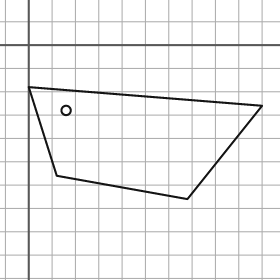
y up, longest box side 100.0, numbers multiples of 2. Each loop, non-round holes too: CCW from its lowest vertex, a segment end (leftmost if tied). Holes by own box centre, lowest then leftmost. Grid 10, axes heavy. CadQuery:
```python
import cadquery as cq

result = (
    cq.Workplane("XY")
    .moveTo(68.0, -66.0)
    .lineTo(100.0, -26.0)
    .lineTo(0.0, -18.0)
    .lineTo(12.0, -56.0)
    .close()
    .moveTo(16.0, -28.0)
    .circle(2.0)
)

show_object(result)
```